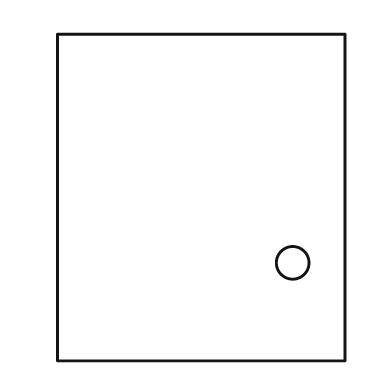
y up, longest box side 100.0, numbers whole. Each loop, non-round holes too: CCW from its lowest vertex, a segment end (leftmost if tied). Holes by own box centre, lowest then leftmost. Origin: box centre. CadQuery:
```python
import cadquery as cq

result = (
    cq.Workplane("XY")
    .moveTo(-44.0, -50.0)
    .lineTo(44.0, -50.0)
    .lineTo(44.0, 50.0)
    .lineTo(-44.0, 50.0)
    .close()
    .moveTo(28.0, -20.0)
    .circle(5.0)
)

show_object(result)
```